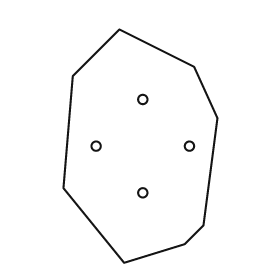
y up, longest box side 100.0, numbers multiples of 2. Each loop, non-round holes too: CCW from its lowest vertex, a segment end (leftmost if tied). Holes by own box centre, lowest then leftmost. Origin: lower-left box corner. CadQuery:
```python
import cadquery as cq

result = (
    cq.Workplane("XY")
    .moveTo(26.0, 0.0)
    .lineTo(52.0, 8.0)
    .lineTo(60.0, 16.0)
    .lineTo(66.0, 62.0)
    .lineTo(56.0, 84.0)
    .lineTo(24.0, 100.0)
    .lineTo(4.0, 80.0)
    .lineTo(0.0, 32.0)
    .close()
    .moveTo(34.0, 30.0)
    .circle(2.0)
    .moveTo(14.0, 50.0)
    .circle(2.0)
    .moveTo(54.0, 50.0)
    .circle(2.0)
    .moveTo(34.0, 70.0)
    .circle(2.0)
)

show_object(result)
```